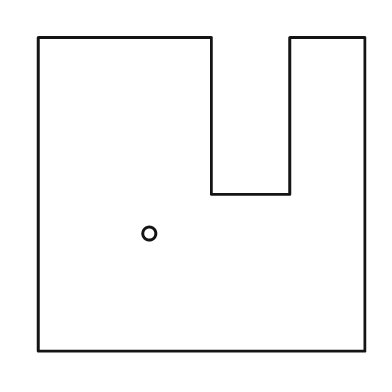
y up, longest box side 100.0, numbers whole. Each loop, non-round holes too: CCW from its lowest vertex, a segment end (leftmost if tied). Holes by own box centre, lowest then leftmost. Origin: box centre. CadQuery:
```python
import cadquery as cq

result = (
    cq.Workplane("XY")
    .moveTo(-50.0, -48.0)
    .lineTo(50.0, -48.0)
    .lineTo(50.0, 48.0)
    .lineTo(27.0, 48.0)
    .lineTo(27.0, 0.0)
    .lineTo(3.0, 0.0)
    .lineTo(3.0, 48.0)
    .lineTo(-50.0, 48.0)
    .close()
    .moveTo(-16.0, -12.0)
    .circle(2.0)
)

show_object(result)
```